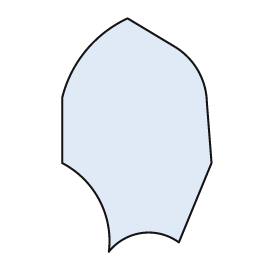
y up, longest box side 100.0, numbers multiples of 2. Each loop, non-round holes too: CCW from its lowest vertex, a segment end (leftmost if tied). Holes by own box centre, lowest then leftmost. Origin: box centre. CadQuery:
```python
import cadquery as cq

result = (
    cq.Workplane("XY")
    .moveTo(-12.0, -50.0)
    .threePointArc((2.0, -42.0), (18.0, -46.0))
    .lineTo(32.0, -12.0)
    .lineTo(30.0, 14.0)
    .threePointArc((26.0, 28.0), (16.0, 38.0))
    .lineTo(-4.0, 50.0)
    .threePointArc((-22.0, 36.0), (-32.0, 16.0))
    .lineTo(-32.0, -12.0)
    .threePointArc((-16.0, -28.0), (-12.0, -50.0))
    .close()
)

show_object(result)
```